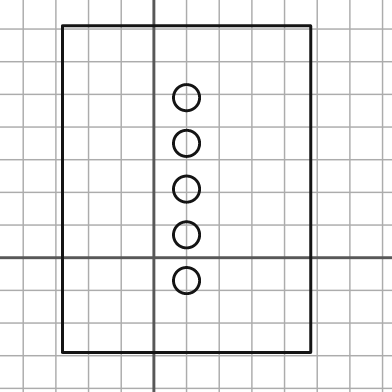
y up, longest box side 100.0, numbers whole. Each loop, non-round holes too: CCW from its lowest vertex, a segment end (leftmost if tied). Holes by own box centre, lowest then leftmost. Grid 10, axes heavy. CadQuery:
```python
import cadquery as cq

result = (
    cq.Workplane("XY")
    .moveTo(-28.0, -29.0)
    .lineTo(48.0, -29.0)
    .lineTo(48.0, 71.0)
    .lineTo(-28.0, 71.0)
    .close()
    .moveTo(10.0, -7.0)
    .circle(4.0)
    .moveTo(10.0, 7.0)
    .circle(4.0)
    .moveTo(10.0, 21.0)
    .circle(4.0)
    .moveTo(10.0, 35.0)
    .circle(4.0)
    .moveTo(10.0, 49.0)
    .circle(4.0)
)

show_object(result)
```